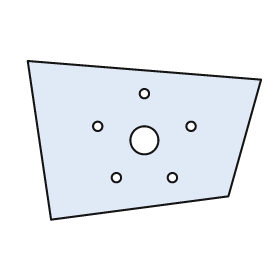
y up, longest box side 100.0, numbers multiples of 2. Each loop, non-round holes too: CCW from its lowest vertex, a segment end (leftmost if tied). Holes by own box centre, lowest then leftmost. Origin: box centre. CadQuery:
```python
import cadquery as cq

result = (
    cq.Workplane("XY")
    .moveTo(-40.0, -34.0)
    .lineTo(36.0, -24.0)
    .lineTo(50.0, 26.0)
    .lineTo(-50.0, 34.0)
    .close()
    .moveTo(-12.0, -16.0)
    .circle(2.0)
    .moveTo(12.0, -16.0)
    .circle(2.0)
    .moveTo(0.0, 0.0)
    .circle(6.0)
    .moveTo(-20.0, 6.0)
    .circle(2.0)
    .moveTo(20.0, 6.0)
    .circle(2.0)
    .moveTo(0.0, 20.0)
    .circle(2.0)
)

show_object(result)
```